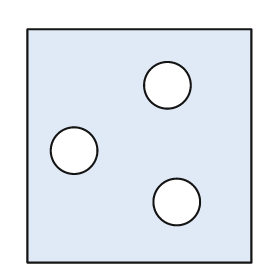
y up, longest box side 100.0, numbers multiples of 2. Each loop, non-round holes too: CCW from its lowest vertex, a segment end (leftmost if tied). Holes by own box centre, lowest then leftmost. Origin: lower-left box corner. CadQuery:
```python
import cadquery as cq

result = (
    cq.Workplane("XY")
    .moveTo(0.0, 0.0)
    .lineTo(96.0, 0.0)
    .lineTo(96.0, 100.0)
    .lineTo(0.0, 100.0)
    .close()
    .moveTo(64.0, 26.0)
    .circle(10.0)
    .moveTo(20.0, 48.0)
    .circle(10.0)
    .moveTo(60.0, 76.0)
    .circle(10.0)
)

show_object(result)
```